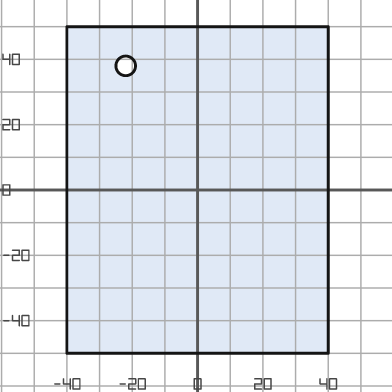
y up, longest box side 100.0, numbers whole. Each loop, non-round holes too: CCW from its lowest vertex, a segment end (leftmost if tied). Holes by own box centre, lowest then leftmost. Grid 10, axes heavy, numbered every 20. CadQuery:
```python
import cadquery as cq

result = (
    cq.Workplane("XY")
    .moveTo(-40.0, -50.0)
    .lineTo(40.0, -50.0)
    .lineTo(40.0, 50.0)
    .lineTo(-40.0, 50.0)
    .close()
    .moveTo(-22.0, 38.0)
    .circle(3.0)
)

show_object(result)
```